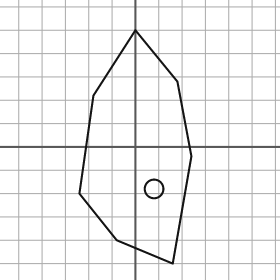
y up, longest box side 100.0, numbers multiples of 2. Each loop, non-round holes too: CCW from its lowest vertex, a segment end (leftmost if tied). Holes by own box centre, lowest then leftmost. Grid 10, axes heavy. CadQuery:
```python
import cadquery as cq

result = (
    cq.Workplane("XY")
    .moveTo(16.0, -50.0)
    .lineTo(24.0, -4.0)
    .lineTo(18.0, 28.0)
    .lineTo(0.0, 50.0)
    .lineTo(-18.0, 22.0)
    .lineTo(-24.0, -20.0)
    .lineTo(-8.0, -40.0)
    .close()
    .moveTo(8.0, -18.0)
    .circle(4.0)
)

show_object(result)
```